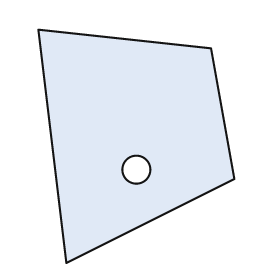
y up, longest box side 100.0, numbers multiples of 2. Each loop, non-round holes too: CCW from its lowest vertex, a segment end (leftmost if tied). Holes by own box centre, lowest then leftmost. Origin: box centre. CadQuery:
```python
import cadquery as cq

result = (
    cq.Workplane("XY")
    .moveTo(-30.0, -50.0)
    .lineTo(42.0, -14.0)
    .lineTo(32.0, 42.0)
    .lineTo(-42.0, 50.0)
    .close()
    .moveTo(0.0, -10.0)
    .circle(6.0)
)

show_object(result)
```